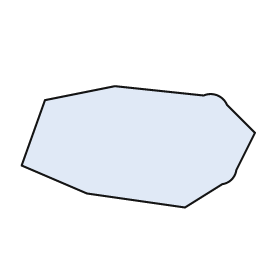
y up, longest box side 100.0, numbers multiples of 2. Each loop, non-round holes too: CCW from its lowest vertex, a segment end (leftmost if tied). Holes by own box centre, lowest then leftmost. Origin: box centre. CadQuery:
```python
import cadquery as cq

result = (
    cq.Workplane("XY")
    .moveTo(20.0, -26.0)
    .lineTo(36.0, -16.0)
    .threePointArc((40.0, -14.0), (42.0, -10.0))
    .lineTo(50.0, 6.0)
    .lineTo(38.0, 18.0)
    .threePointArc((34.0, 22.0), (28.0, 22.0))
    .lineTo(-10.0, 26.0)
    .lineTo(-40.0, 20.0)
    .lineTo(-50.0, -8.0)
    .lineTo(-22.0, -20.0)
    .close()
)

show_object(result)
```